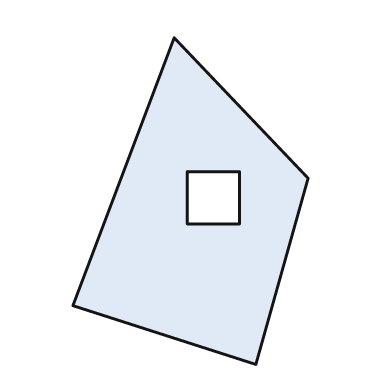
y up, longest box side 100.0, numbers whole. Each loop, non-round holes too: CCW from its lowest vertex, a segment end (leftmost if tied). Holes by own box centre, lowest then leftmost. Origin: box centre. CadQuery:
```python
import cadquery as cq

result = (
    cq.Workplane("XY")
    .moveTo(20.0, -50.0)
    .lineTo(36.0, 7.0)
    .lineTo(-5.0, 50.0)
    .lineTo(-36.0, -32.0)
    .close()
    .moveTo(-1.0, -7.0)
    .lineTo(15.0, -7.0)
    .lineTo(15.0, 9.0)
    .lineTo(-1.0, 9.0)
    .close()
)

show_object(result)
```